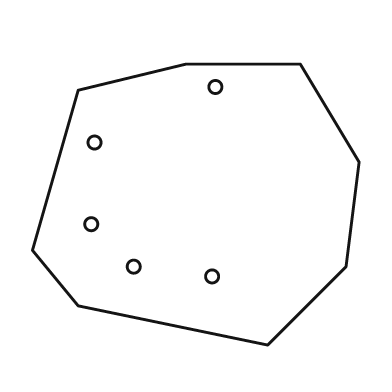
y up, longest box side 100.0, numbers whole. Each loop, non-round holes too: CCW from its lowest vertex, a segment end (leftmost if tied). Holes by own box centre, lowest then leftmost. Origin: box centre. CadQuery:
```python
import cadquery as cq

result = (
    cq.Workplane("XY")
    .moveTo(22.0, -43.0)
    .lineTo(46.0, -19.0)
    .lineTo(50.0, 13.0)
    .lineTo(32.0, 43.0)
    .lineTo(-3.0, 43.0)
    .lineTo(-36.0, 35.0)
    .lineTo(-50.0, -14.0)
    .lineTo(-36.0, -31.0)
    .close()
    .moveTo(5.0, -22.0)
    .circle(2.0)
    .moveTo(-19.0, -19.0)
    .circle(2.0)
    .moveTo(-32.0, -6.0)
    .circle(2.0)
    .moveTo(-31.0, 19.0)
    .circle(2.0)
    .moveTo(6.0, 36.0)
    .circle(2.0)
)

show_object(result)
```